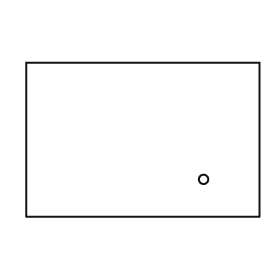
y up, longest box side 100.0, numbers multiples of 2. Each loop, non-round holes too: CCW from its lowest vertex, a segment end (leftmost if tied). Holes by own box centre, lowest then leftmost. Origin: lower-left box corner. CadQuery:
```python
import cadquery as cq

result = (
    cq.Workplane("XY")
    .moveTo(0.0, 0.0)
    .lineTo(100.0, 0.0)
    .lineTo(100.0, 66.0)
    .lineTo(0.0, 66.0)
    .close()
    .moveTo(76.0, 16.0)
    .circle(2.0)
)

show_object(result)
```